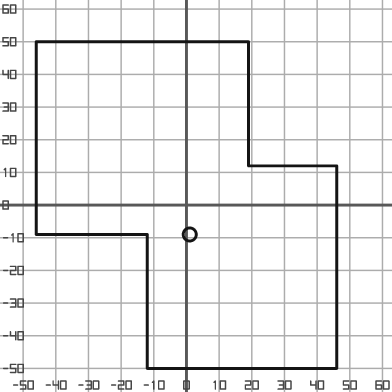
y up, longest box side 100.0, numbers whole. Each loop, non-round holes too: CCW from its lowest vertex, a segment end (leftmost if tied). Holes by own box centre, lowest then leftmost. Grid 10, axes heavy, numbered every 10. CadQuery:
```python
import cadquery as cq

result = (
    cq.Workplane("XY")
    .moveTo(-12.0, -50.0)
    .lineTo(46.0, -50.0)
    .lineTo(46.0, 12.0)
    .lineTo(19.0, 12.0)
    .lineTo(19.0, 50.0)
    .lineTo(-46.0, 50.0)
    .lineTo(-46.0, -9.0)
    .lineTo(-12.0, -9.0)
    .close()
    .moveTo(1.0, -9.0)
    .circle(2.0)
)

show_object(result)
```